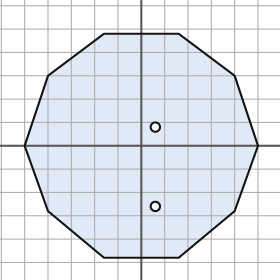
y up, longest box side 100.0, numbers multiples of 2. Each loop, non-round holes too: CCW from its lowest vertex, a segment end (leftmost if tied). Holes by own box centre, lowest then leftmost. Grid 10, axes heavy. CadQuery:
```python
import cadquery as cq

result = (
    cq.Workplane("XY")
    .moveTo(-16.0, -48.0)
    .lineTo(16.0, -48.0)
    .lineTo(40.0, -28.0)
    .lineTo(50.0, 0.0)
    .lineTo(40.0, 30.0)
    .lineTo(16.0, 48.0)
    .lineTo(-16.0, 48.0)
    .lineTo(-40.0, 30.0)
    .lineTo(-50.0, 0.0)
    .lineTo(-40.0, -28.0)
    .close()
    .moveTo(6.0, -26.0)
    .circle(2.0)
    .moveTo(6.0, 8.0)
    .circle(2.0)
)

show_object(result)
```